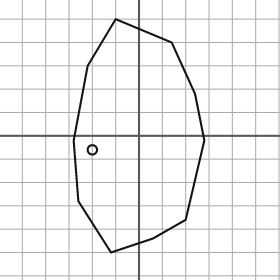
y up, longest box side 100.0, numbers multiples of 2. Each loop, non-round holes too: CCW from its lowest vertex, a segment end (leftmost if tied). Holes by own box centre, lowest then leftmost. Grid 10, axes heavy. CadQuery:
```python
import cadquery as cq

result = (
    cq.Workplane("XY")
    .moveTo(-12.0, -50.0)
    .lineTo(6.0, -44.0)
    .lineTo(20.0, -36.0)
    .lineTo(28.0, -2.0)
    .lineTo(24.0, 18.0)
    .lineTo(14.0, 40.0)
    .lineTo(-10.0, 50.0)
    .lineTo(-22.0, 30.0)
    .lineTo(-28.0, -2.0)
    .lineTo(-26.0, -28.0)
    .close()
    .moveTo(-20.0, -6.0)
    .circle(2.0)
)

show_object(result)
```